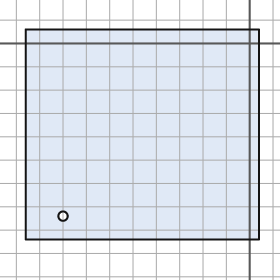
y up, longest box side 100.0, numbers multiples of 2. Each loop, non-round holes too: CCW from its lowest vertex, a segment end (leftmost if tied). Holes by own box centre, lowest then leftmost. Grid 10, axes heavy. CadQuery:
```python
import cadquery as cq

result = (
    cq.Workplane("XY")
    .moveTo(-96.0, -84.0)
    .lineTo(4.0, -84.0)
    .lineTo(4.0, 6.0)
    .lineTo(-96.0, 6.0)
    .close()
    .moveTo(-80.0, -74.0)
    .circle(2.0)
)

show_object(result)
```